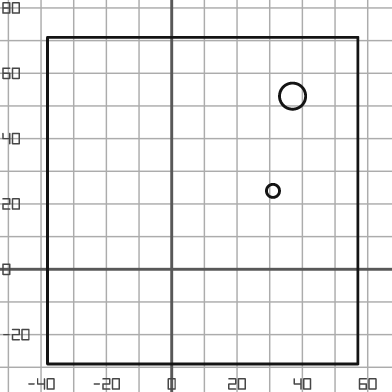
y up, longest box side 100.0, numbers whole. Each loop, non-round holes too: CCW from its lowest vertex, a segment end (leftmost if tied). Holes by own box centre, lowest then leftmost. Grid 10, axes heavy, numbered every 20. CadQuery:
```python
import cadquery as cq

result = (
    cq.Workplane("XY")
    .moveTo(-38.0, -29.0)
    .lineTo(57.0, -29.0)
    .lineTo(57.0, 71.0)
    .lineTo(-38.0, 71.0)
    .close()
    .moveTo(31.0, 24.0)
    .circle(2.0)
    .moveTo(37.0, 53.0)
    .circle(4.0)
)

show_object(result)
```